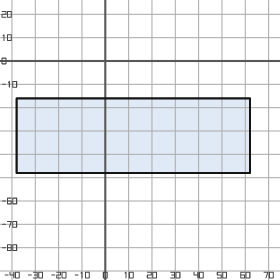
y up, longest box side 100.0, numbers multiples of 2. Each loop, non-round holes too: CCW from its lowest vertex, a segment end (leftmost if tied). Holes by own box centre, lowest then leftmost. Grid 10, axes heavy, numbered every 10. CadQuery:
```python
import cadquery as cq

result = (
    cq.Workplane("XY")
    .moveTo(-38.0, -48.0)
    .lineTo(62.0, -48.0)
    .lineTo(62.0, -16.0)
    .lineTo(-38.0, -16.0)
    .close()
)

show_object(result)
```